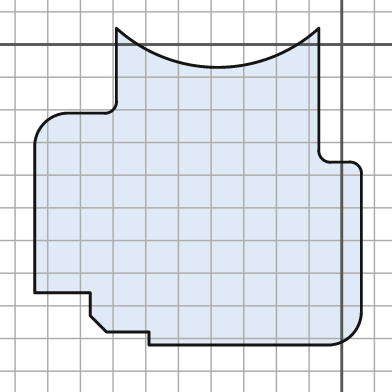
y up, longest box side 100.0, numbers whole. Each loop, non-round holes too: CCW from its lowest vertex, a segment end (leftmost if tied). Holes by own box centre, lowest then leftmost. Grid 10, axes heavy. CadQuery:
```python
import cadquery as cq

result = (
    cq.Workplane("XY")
    .moveTo(-59.0, -92.0)
    .lineTo(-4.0, -92.0)
    .threePointArc((3.0, -89.0), (6.0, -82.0))
    .lineTo(6.0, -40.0)
    .threePointArc((5.0, -37.0), (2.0, -36.0))
    .lineTo(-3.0, -36.0)
    .threePointArc((-6.0, -35.0), (-7.0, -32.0))
    .lineTo(-7.0, 5.0)
    .threePointArc((-38.0, -7.0), (-69.0, 5.0))
    .lineTo(-69.0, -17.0)
    .threePointArc((-70.0, -20.0), (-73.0, -21.0))
    .lineTo(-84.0, -21.0)
    .threePointArc((-91.0, -24.0), (-94.0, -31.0))
    .lineTo(-94.0, -76.0)
    .lineTo(-77.0, -76.0)
    .lineTo(-77.0, -83.0)
    .lineTo(-72.0, -88.0)
    .lineTo(-59.0, -88.0)
    .close()
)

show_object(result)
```